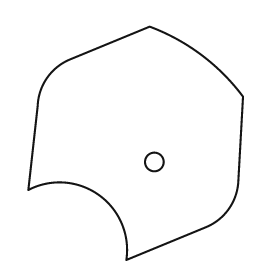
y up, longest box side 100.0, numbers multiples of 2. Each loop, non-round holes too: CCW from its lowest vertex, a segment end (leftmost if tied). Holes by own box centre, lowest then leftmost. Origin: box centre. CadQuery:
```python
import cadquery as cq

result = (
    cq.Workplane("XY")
    .moveTo(-4.0, -50.0)
    .lineTo(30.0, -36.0)
    .threePointArc((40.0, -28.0), (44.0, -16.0))
    .lineTo(46.0, 20.0)
    .threePointArc((28.0, 38.0), (6.0, 50.0))
    .lineTo(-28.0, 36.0)
    .threePointArc((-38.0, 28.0), (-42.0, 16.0))
    .lineTo(-46.0, -20.0)
    .threePointArc((-16.0, -22.0), (-4.0, -50.0))
    .close()
    .moveTo(8.0, -8.0)
    .circle(4.0)
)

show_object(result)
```